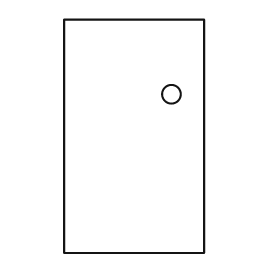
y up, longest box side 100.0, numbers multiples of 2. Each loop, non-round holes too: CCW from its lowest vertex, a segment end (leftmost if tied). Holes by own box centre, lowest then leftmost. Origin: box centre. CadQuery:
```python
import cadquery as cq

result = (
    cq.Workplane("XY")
    .moveTo(-30.0, -50.0)
    .lineTo(30.0, -50.0)
    .lineTo(30.0, 50.0)
    .lineTo(-30.0, 50.0)
    .close()
    .moveTo(16.0, 18.0)
    .circle(4.0)
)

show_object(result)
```